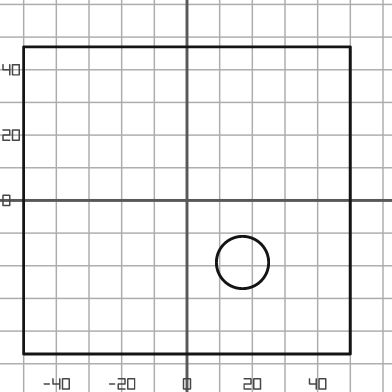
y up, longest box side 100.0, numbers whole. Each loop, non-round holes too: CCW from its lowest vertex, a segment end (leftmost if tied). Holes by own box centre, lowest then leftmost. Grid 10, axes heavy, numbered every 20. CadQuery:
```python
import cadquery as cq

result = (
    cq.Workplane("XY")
    .moveTo(-50.0, -47.0)
    .lineTo(50.0, -47.0)
    .lineTo(50.0, 47.0)
    .lineTo(-50.0, 47.0)
    .close()
    .moveTo(17.0, -19.0)
    .circle(8.0)
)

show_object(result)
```